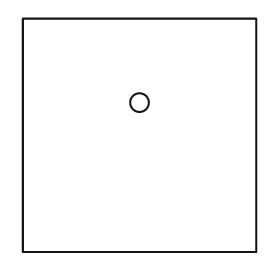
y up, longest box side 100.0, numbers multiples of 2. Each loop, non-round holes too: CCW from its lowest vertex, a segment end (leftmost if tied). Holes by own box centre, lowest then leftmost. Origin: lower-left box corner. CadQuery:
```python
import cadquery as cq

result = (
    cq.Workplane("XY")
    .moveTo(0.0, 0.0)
    .lineTo(100.0, 0.0)
    .lineTo(100.0, 100.0)
    .lineTo(0.0, 100.0)
    .close()
    .moveTo(50.0, 64.0)
    .circle(4.0)
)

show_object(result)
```